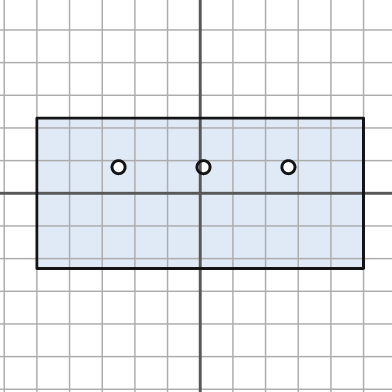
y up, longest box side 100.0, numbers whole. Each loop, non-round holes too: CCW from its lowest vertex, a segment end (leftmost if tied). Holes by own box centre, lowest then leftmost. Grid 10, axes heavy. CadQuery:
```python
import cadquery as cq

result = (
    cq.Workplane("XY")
    .moveTo(-50.0, -23.0)
    .lineTo(50.0, -23.0)
    .lineTo(50.0, 23.0)
    .lineTo(-50.0, 23.0)
    .close()
    .moveTo(-25.0, 8.0)
    .circle(2.0)
    .moveTo(1.0, 8.0)
    .circle(2.0)
    .moveTo(27.0, 8.0)
    .circle(2.0)
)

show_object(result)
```